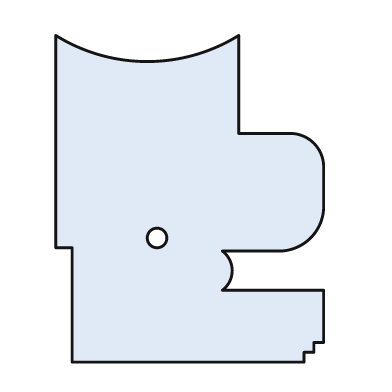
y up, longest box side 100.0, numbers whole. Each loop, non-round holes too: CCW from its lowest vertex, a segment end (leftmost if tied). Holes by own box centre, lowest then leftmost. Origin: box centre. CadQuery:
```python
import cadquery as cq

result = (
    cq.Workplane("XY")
    .moveTo(-36.0, -50.0)
    .lineTo(35.0, -50.0)
    .lineTo(35.0, -47.0)
    .lineTo(38.0, -47.0)
    .lineTo(38.0, -44.0)
    .lineTo(41.0, -44.0)
    .lineTo(41.0, -28.0)
    .lineTo(10.0, -28.0)
    .threePointArc((13.0, -22.0), (10.0, -16.0))
    .lineTo(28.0, -16.0)
    .threePointArc((37.0, -12.0), (41.0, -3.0))
    .lineTo(41.0, 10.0)
    .threePointArc((38.0, 17.0), (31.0, 20.0))
    .lineTo(15.0, 20.0)
    .lineTo(15.0, 50.0)
    .threePointArc((-13.0, 42.0), (-41.0, 50.0))
    .lineTo(-41.0, -15.0)
    .lineTo(-36.0, -15.0)
    .close()
    .moveTo(-10.0, -12.0)
    .circle(3.0)
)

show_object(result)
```